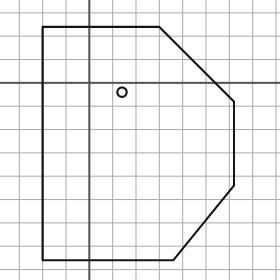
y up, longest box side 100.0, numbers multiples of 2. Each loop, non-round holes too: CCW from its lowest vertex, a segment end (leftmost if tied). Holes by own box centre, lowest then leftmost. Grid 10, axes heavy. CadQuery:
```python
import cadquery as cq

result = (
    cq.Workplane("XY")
    .moveTo(-20.0, -76.0)
    .lineTo(36.0, -76.0)
    .lineTo(62.0, -44.0)
    .lineTo(62.0, -8.0)
    .lineTo(30.0, 24.0)
    .lineTo(-20.0, 24.0)
    .close()
    .moveTo(14.0, -4.0)
    .circle(2.0)
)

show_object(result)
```